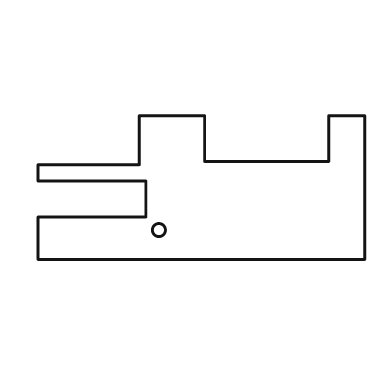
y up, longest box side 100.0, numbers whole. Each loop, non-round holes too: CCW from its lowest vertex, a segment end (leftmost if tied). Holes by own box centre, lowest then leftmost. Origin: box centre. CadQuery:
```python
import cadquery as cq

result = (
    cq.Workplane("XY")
    .moveTo(-50.0, -22.0)
    .lineTo(50.0, -22.0)
    .lineTo(50.0, 22.0)
    .lineTo(39.0, 22.0)
    .lineTo(39.0, 8.0)
    .lineTo(1.0, 8.0)
    .lineTo(1.0, 22.0)
    .lineTo(-19.0, 22.0)
    .lineTo(-19.0, 7.0)
    .lineTo(-50.0, 7.0)
    .lineTo(-50.0, 2.0)
    .lineTo(-17.0, 2.0)
    .lineTo(-17.0, -9.0)
    .lineTo(-50.0, -9.0)
    .close()
    .moveTo(-13.0, -13.0)
    .circle(2.0)
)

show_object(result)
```